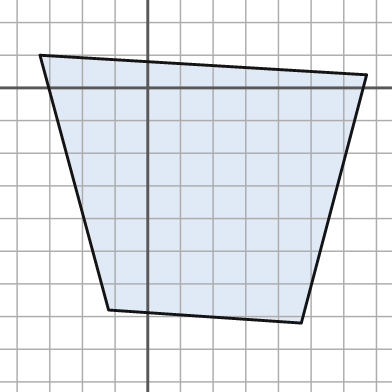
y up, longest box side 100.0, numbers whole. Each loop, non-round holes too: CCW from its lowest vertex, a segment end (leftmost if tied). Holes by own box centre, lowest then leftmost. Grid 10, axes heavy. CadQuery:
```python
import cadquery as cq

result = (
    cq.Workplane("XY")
    .moveTo(47.0, -72.0)
    .lineTo(67.0, 4.0)
    .lineTo(-33.0, 10.0)
    .lineTo(-12.0, -68.0)
    .close()
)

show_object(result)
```